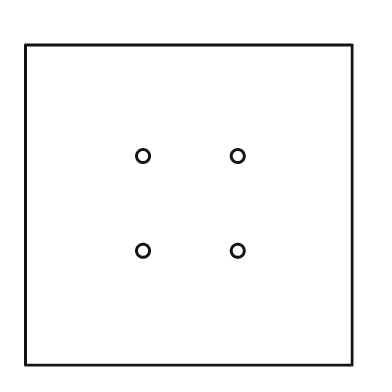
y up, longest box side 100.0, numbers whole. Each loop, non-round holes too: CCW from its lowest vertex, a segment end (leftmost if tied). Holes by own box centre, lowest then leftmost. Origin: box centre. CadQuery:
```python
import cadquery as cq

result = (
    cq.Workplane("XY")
    .moveTo(-50.0, -49.0)
    .lineTo(50.0, -49.0)
    .lineTo(50.0, 49.0)
    .lineTo(-50.0, 49.0)
    .close()
    .moveTo(-14.0, -14.0)
    .circle(2.0)
    .moveTo(15.0, -14.0)
    .circle(2.0)
    .moveTo(-14.0, 15.0)
    .circle(2.0)
    .moveTo(15.0, 15.0)
    .circle(2.0)
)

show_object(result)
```